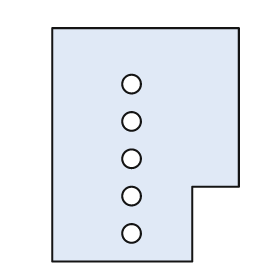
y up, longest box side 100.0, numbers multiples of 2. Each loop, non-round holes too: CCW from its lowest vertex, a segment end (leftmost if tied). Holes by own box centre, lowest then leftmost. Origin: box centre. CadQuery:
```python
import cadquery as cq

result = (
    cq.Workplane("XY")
    .moveTo(-40.0, -50.0)
    .lineTo(20.0, -50.0)
    .lineTo(20.0, -18.0)
    .lineTo(40.0, -18.0)
    .lineTo(40.0, 50.0)
    .lineTo(-40.0, 50.0)
    .close()
    .moveTo(-6.0, -38.0)
    .circle(4.0)
    .moveTo(-6.0, -22.0)
    .circle(4.0)
    .moveTo(-6.0, -6.0)
    .circle(4.0)
    .moveTo(-6.0, 10.0)
    .circle(4.0)
    .moveTo(-6.0, 26.0)
    .circle(4.0)
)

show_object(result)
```